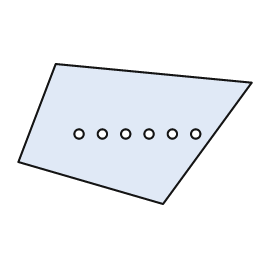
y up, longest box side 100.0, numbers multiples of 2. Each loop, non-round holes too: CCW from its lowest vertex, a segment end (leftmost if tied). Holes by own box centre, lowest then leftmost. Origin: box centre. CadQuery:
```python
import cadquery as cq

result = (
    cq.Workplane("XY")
    .moveTo(12.0, -30.0)
    .lineTo(50.0, 22.0)
    .lineTo(-34.0, 30.0)
    .lineTo(-50.0, -12.0)
    .close()
    .moveTo(-24.0, 0.0)
    .circle(2.0)
    .moveTo(-14.0, 0.0)
    .circle(2.0)
    .moveTo(-4.0, 0.0)
    .circle(2.0)
    .moveTo(6.0, 0.0)
    .circle(2.0)
    .moveTo(16.0, 0.0)
    .circle(2.0)
    .moveTo(26.0, 0.0)
    .circle(2.0)
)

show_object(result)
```